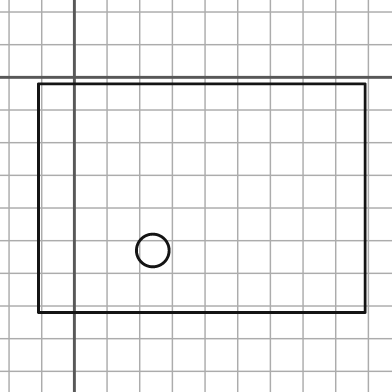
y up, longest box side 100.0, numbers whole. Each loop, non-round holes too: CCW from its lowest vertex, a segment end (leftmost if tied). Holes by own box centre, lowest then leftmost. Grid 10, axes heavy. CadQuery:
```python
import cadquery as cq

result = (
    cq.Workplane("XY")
    .moveTo(-11.0, -72.0)
    .lineTo(89.0, -72.0)
    .lineTo(89.0, -2.0)
    .lineTo(-11.0, -2.0)
    .close()
    .moveTo(24.0, -53.0)
    .circle(5.0)
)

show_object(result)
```